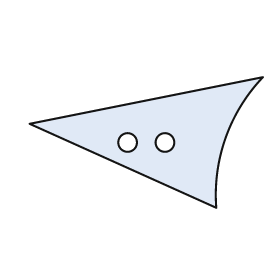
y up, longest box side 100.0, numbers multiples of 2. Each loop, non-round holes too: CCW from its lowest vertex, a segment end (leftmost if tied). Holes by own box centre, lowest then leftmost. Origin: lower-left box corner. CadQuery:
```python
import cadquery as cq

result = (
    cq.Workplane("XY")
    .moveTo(80.0, 0.0)
    .threePointArc((84.0, 30.0), (100.0, 56.0))
    .lineTo(0.0, 36.0)
    .close()
    .moveTo(42.0, 28.0)
    .circle(4.0)
    .moveTo(58.0, 28.0)
    .circle(4.0)
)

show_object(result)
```